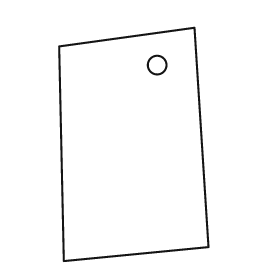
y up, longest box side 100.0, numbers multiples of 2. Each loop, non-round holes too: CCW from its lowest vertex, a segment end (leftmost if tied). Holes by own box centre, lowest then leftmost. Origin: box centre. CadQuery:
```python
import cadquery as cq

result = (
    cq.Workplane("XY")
    .moveTo(-30.0, -50.0)
    .lineTo(32.0, -44.0)
    .lineTo(26.0, 50.0)
    .lineTo(-32.0, 42.0)
    .close()
    .moveTo(10.0, 34.0)
    .circle(4.0)
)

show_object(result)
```